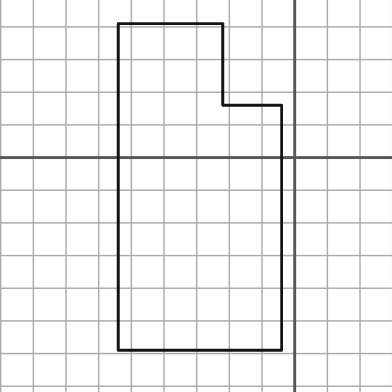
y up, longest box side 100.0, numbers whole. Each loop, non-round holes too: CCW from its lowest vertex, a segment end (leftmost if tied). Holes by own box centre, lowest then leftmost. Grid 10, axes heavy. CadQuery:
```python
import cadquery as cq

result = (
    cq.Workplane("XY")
    .moveTo(-54.0, -59.0)
    .lineTo(-4.0, -59.0)
    .lineTo(-4.0, 16.0)
    .lineTo(-22.0, 16.0)
    .lineTo(-22.0, 41.0)
    .lineTo(-54.0, 41.0)
    .close()
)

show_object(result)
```